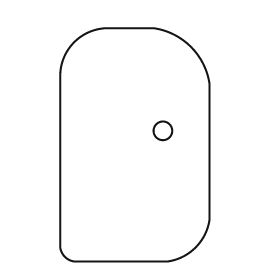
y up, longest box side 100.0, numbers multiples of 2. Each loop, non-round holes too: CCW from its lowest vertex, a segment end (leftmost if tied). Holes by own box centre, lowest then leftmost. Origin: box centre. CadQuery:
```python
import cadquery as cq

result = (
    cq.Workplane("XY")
    .moveTo(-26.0, -50.0)
    .lineTo(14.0, -50.0)
    .threePointArc((26.0, -44.0), (32.0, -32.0))
    .lineTo(32.0, 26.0)
    .threePointArc((24.0, 42.0), (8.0, 50.0))
    .lineTo(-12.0, 50.0)
    .threePointArc((-26.0, 44.0), (-32.0, 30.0))
    .lineTo(-32.0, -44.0)
    .threePointArc((-30.0, -48.0), (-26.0, -50.0))
    .close()
    .moveTo(12.0, 6.0)
    .circle(4.0)
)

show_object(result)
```